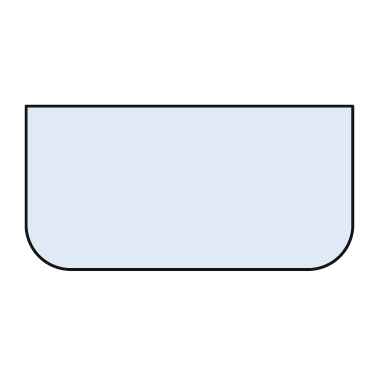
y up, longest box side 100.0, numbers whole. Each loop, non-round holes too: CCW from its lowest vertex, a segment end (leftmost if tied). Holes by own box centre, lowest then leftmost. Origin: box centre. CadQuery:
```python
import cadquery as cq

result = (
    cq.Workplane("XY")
    .moveTo(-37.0, -25.0)
    .lineTo(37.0, -25.0)
    .threePointArc((46.0, -21.0), (50.0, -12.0))
    .lineTo(50.0, 25.0)
    .lineTo(-50.0, 25.0)
    .lineTo(-50.0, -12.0)
    .threePointArc((-46.0, -21.0), (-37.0, -25.0))
    .close()
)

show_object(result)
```